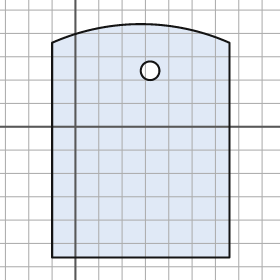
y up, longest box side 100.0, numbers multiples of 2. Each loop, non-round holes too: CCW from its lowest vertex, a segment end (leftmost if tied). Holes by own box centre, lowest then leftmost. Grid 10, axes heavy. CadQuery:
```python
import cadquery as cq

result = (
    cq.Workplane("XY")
    .moveTo(-10.0, -56.0)
    .lineTo(66.0, -56.0)
    .lineTo(66.0, 36.0)
    .threePointArc((28.0, 44.0), (-10.0, 36.0))
    .close()
    .moveTo(32.0, 24.0)
    .circle(4.0)
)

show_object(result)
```